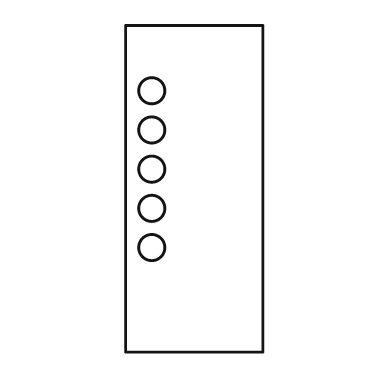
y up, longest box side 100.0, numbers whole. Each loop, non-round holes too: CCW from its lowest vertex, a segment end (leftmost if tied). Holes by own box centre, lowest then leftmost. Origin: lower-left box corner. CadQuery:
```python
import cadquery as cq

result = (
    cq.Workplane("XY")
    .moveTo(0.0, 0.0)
    .lineTo(42.0, 0.0)
    .lineTo(42.0, 100.0)
    .lineTo(0.0, 100.0)
    .close()
    .moveTo(8.0, 32.0)
    .circle(4.0)
    .moveTo(8.0, 44.0)
    .circle(4.0)
    .moveTo(8.0, 56.0)
    .circle(4.0)
    .moveTo(8.0, 68.0)
    .circle(4.0)
    .moveTo(8.0, 80.0)
    .circle(4.0)
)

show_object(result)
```